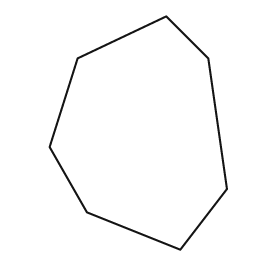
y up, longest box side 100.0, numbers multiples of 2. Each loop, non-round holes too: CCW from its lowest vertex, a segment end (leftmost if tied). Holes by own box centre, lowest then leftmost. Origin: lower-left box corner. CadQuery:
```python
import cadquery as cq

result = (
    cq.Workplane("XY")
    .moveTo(56.0, 0.0)
    .lineTo(76.0, 26.0)
    .lineTo(68.0, 82.0)
    .lineTo(50.0, 100.0)
    .lineTo(12.0, 82.0)
    .lineTo(0.0, 44.0)
    .lineTo(16.0, 16.0)
    .close()
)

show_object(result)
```